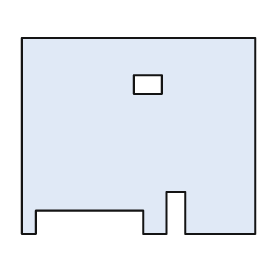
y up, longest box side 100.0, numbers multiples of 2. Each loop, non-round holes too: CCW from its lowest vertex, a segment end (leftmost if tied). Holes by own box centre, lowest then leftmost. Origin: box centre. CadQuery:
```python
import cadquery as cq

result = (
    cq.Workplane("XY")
    .moveTo(-50.0, -42.0)
    .lineTo(-44.0, -42.0)
    .lineTo(-44.0, -32.0)
    .lineTo(2.0, -32.0)
    .lineTo(2.0, -42.0)
    .lineTo(12.0, -42.0)
    .lineTo(12.0, -24.0)
    .lineTo(20.0, -24.0)
    .lineTo(20.0, -42.0)
    .lineTo(50.0, -42.0)
    .lineTo(50.0, 42.0)
    .lineTo(-50.0, 42.0)
    .close()
    .moveTo(-2.0, 18.0)
    .lineTo(10.0, 18.0)
    .lineTo(10.0, 26.0)
    .lineTo(-2.0, 26.0)
    .close()
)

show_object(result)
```